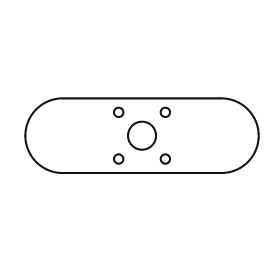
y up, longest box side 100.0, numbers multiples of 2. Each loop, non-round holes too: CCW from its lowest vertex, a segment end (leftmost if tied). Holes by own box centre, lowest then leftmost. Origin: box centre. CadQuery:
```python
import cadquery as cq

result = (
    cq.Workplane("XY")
    .moveTo(-34.0, -16.0)
    .lineTo(34.0, -16.0)
    .threePointArc((50.0, 0.0), (34.0, 16.0))
    .lineTo(-34.0, 16.0)
    .threePointArc((-50.0, 0.0), (-34.0, -16.0))
    .close()
    .moveTo(-10.0, -10.0)
    .circle(2.0)
    .moveTo(10.0, -10.0)
    .circle(2.0)
    .moveTo(0.0, 0.0)
    .circle(6.0)
    .moveTo(-10.0, 10.0)
    .circle(2.0)
    .moveTo(10.0, 10.0)
    .circle(2.0)
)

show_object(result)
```